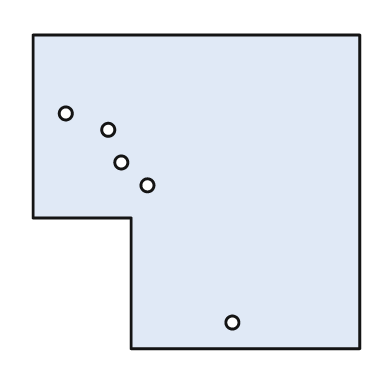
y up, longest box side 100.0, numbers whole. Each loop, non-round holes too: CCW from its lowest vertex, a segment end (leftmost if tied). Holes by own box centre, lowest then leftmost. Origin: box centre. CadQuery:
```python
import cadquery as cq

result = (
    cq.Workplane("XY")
    .moveTo(-20.0, -48.0)
    .lineTo(50.0, -48.0)
    .lineTo(50.0, 48.0)
    .lineTo(-50.0, 48.0)
    .lineTo(-50.0, -8.0)
    .lineTo(-20.0, -8.0)
    .close()
    .moveTo(11.0, -40.0)
    .circle(2.0)
    .moveTo(-15.0, 2.0)
    .circle(2.0)
    .moveTo(-23.0, 9.0)
    .circle(2.0)
    .moveTo(-27.0, 19.0)
    .circle(2.0)
    .moveTo(-40.0, 24.0)
    .circle(2.0)
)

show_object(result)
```